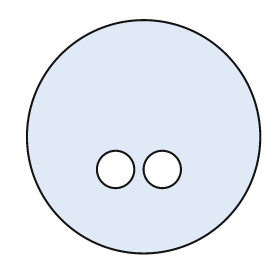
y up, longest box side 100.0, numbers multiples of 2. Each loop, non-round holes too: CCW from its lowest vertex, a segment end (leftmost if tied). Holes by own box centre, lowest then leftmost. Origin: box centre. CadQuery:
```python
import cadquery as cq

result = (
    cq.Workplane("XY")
    .moveTo(0.0, 0.0)
    .circle(50.0)
    .moveTo(-12.0, -14.0)
    .circle(8.0)
    .moveTo(8.0, -14.0)
    .circle(8.0)
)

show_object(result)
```